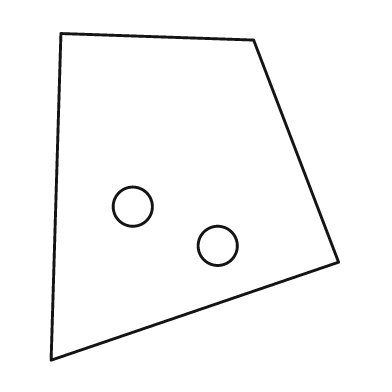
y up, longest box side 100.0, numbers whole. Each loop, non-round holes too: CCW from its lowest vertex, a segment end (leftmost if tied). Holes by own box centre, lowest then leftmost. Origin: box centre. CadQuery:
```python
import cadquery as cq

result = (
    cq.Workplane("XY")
    .moveTo(-44.0, -50.0)
    .lineTo(44.0, -20.0)
    .lineTo(18.0, 48.0)
    .lineTo(-41.0, 50.0)
    .close()
    .moveTo(7.0, -15.0)
    .circle(6.0)
    .moveTo(-19.0, -3.0)
    .circle(6.0)
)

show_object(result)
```